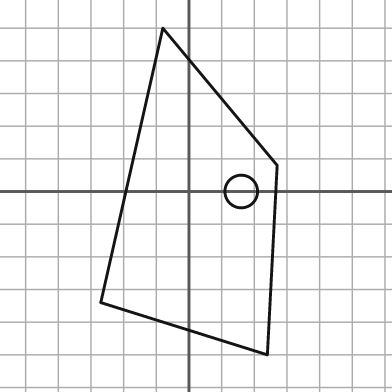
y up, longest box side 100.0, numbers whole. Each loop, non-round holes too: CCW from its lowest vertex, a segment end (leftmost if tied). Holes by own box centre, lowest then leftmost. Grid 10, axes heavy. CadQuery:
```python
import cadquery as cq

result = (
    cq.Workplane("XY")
    .moveTo(24.0, -50.0)
    .lineTo(27.0, 8.0)
    .lineTo(-8.0, 50.0)
    .lineTo(-27.0, -34.0)
    .close()
    .moveTo(16.0, 0.0)
    .circle(5.0)
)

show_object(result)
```